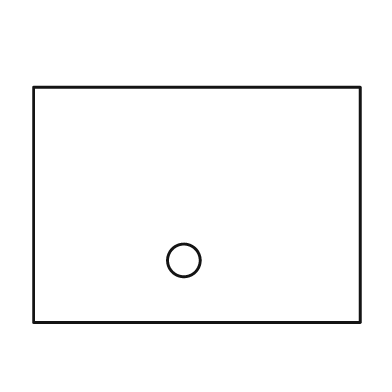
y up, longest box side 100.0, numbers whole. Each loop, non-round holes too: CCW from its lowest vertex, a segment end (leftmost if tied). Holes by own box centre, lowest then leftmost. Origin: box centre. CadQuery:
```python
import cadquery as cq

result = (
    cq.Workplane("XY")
    .moveTo(-50.0, -36.0)
    .lineTo(50.0, -36.0)
    .lineTo(50.0, 36.0)
    .lineTo(-50.0, 36.0)
    .close()
    .moveTo(-4.0, -17.0)
    .circle(5.0)
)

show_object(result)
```